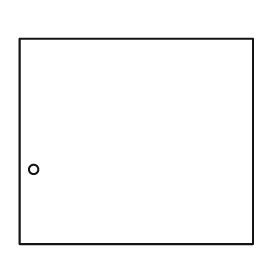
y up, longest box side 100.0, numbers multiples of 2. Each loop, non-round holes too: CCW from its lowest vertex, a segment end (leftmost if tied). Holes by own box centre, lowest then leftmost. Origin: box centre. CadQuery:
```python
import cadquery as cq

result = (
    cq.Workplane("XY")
    .moveTo(-50.0, -44.0)
    .lineTo(50.0, -44.0)
    .lineTo(50.0, 44.0)
    .lineTo(-50.0, 44.0)
    .close()
    .moveTo(-44.0, -12.0)
    .circle(2.0)
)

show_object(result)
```